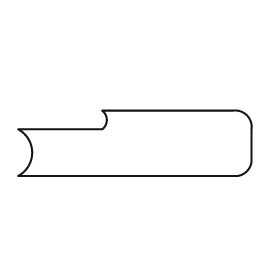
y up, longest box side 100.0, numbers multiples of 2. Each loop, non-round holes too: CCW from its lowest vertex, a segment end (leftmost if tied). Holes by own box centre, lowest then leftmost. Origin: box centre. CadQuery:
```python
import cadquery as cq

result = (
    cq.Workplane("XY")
    .moveTo(-50.0, -14.0)
    .lineTo(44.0, -14.0)
    .threePointArc((48.0, -12.0), (50.0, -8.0))
    .lineTo(50.0, 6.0)
    .threePointArc((48.0, 12.0), (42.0, 14.0))
    .lineTo(-14.0, 14.0)
    .threePointArc((-12.0, 10.0), (-14.0, 6.0))
    .lineTo(-50.0, 6.0)
    .threePointArc((-44.0, -4.0), (-50.0, -14.0))
    .close()
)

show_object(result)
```